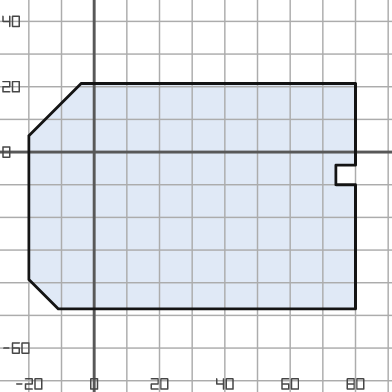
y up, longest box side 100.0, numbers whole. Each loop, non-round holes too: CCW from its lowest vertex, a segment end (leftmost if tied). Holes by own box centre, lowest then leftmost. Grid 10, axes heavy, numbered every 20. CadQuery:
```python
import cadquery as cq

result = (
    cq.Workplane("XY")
    .moveTo(-11.0, -48.0)
    .lineTo(80.0, -48.0)
    .lineTo(80.0, -10.0)
    .lineTo(74.0, -10.0)
    .lineTo(74.0, -4.0)
    .lineTo(80.0, -4.0)
    .lineTo(80.0, 21.0)
    .lineTo(-4.0, 21.0)
    .lineTo(-20.0, 5.0)
    .lineTo(-20.0, -39.0)
    .close()
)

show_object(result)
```